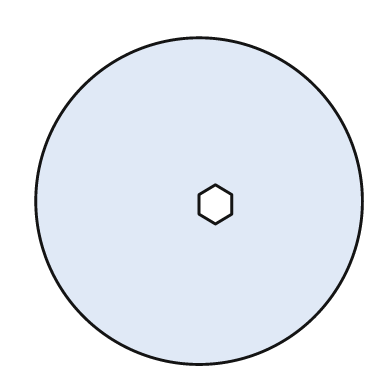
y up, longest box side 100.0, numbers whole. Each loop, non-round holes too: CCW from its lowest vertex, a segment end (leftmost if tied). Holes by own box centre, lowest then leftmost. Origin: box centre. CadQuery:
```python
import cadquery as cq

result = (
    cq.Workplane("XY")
    .moveTo(0.0, 0.0)
    .circle(50.0)
    .moveTo(5.0, -7.0)
    .lineTo(10.0, -4.0)
    .lineTo(10.0, 2.0)
    .lineTo(5.0, 5.0)
    .lineTo(0.0, 2.0)
    .lineTo(0.0, -4.0)
    .close()
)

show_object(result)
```